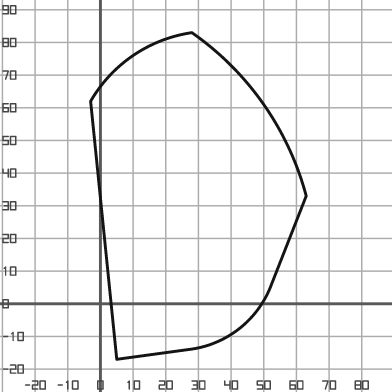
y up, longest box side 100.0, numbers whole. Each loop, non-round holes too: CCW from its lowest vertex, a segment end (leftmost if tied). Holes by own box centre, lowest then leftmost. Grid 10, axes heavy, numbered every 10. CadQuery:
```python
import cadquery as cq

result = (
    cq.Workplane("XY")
    .moveTo(5.0, -17.0)
    .lineTo(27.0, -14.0)
    .threePointArc((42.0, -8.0), (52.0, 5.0))
    .lineTo(63.0, 33.0)
    .threePointArc((50.0, 61.0), (28.0, 83.0))
    .threePointArc((10.0, 76.0), (-3.0, 62.0))
    .close()
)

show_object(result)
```